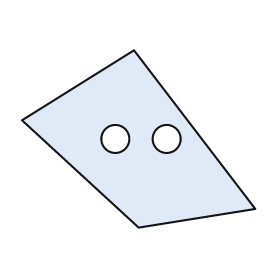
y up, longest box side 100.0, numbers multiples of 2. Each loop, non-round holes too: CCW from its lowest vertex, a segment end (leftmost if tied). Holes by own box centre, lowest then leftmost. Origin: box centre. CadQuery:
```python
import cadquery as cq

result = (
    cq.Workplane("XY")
    .moveTo(0.0, -38.0)
    .lineTo(50.0, -30.0)
    .lineTo(-2.0, 38.0)
    .lineTo(-50.0, 8.0)
    .close()
    .moveTo(-10.0, 0.0)
    .circle(6.0)
    .moveTo(12.0, 0.0)
    .circle(6.0)
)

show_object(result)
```